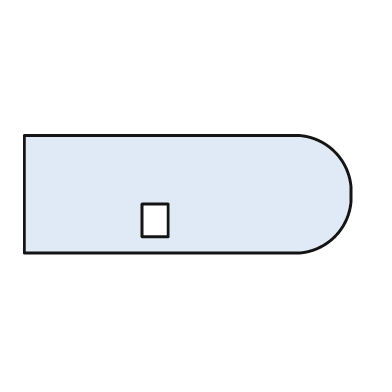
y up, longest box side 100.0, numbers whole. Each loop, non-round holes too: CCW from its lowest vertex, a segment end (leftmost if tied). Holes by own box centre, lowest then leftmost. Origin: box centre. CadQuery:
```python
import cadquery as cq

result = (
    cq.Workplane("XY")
    .moveTo(-50.0, -18.0)
    .lineTo(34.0, -18.0)
    .threePointArc((45.0, -13.0), (50.0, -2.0))
    .lineTo(50.0, 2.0)
    .threePointArc((45.0, 13.0), (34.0, 18.0))
    .lineTo(-50.0, 18.0)
    .close()
    .moveTo(-14.0, -13.0)
    .lineTo(-6.0, -13.0)
    .lineTo(-6.0, -3.0)
    .lineTo(-14.0, -3.0)
    .close()
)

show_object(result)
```